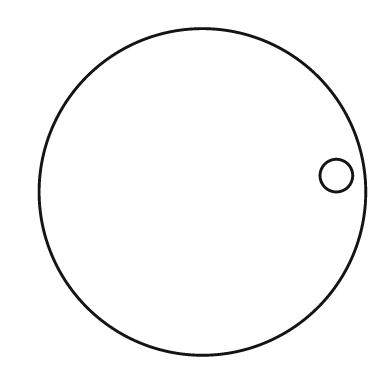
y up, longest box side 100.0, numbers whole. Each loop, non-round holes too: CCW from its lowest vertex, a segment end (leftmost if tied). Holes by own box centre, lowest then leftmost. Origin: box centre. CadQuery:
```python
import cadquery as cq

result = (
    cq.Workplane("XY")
    .moveTo(0.0, 0.0)
    .circle(50.0)
    .moveTo(41.0, 5.0)
    .circle(5.0)
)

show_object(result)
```